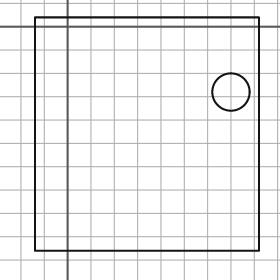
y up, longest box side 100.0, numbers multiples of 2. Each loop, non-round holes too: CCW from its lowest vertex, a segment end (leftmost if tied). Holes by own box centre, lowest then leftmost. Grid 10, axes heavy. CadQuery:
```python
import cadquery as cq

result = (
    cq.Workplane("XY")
    .moveTo(-14.0, -96.0)
    .lineTo(82.0, -96.0)
    .lineTo(82.0, 4.0)
    .lineTo(-14.0, 4.0)
    .close()
    .moveTo(70.0, -28.0)
    .circle(8.0)
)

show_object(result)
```